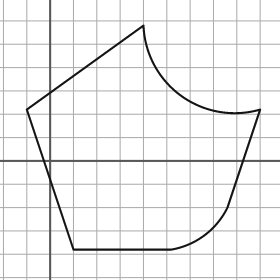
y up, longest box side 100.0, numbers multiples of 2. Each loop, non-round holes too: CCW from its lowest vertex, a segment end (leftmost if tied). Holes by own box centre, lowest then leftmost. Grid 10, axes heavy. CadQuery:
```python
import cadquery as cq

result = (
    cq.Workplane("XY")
    .moveTo(10.0, -38.0)
    .lineTo(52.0, -38.0)
    .threePointArc((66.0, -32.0), (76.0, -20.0))
    .lineTo(90.0, 22.0)
    .threePointArc((56.0, 28.0), (40.0, 58.0))
    .lineTo(-10.0, 22.0)
    .close()
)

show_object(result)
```